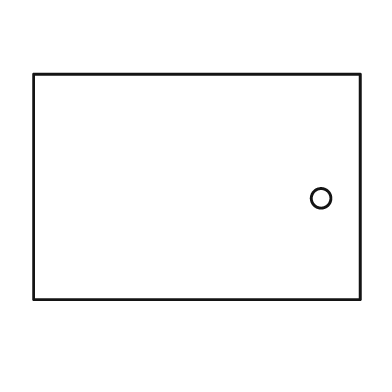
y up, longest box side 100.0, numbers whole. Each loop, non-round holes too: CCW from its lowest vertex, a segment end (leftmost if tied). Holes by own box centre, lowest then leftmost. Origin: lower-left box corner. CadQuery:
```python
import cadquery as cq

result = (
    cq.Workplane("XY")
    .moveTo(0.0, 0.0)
    .lineTo(100.0, 0.0)
    .lineTo(100.0, 69.0)
    .lineTo(0.0, 69.0)
    .close()
    .moveTo(88.0, 31.0)
    .circle(3.0)
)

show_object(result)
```